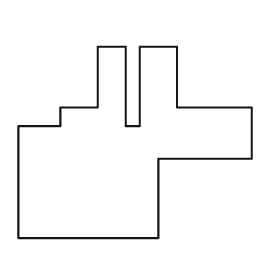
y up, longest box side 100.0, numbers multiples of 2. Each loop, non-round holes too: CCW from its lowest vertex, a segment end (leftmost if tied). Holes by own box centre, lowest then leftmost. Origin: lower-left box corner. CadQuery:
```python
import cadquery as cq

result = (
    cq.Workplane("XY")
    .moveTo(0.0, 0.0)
    .lineTo(60.0, 0.0)
    .lineTo(60.0, 34.0)
    .lineTo(100.0, 34.0)
    .lineTo(100.0, 56.0)
    .lineTo(68.0, 56.0)
    .lineTo(68.0, 82.0)
    .lineTo(52.0, 82.0)
    .lineTo(52.0, 48.0)
    .lineTo(46.0, 48.0)
    .lineTo(46.0, 82.0)
    .lineTo(34.0, 82.0)
    .lineTo(34.0, 56.0)
    .lineTo(18.0, 56.0)
    .lineTo(18.0, 48.0)
    .lineTo(0.0, 48.0)
    .close()
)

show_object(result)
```